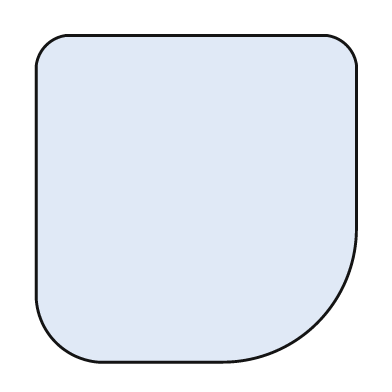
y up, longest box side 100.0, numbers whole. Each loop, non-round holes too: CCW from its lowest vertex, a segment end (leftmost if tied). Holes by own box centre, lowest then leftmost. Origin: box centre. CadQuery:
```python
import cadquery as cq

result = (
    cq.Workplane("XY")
    .moveTo(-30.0, -50.0)
    .lineTo(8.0, -50.0)
    .threePointArc((37.0, -38.0), (49.0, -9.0))
    .lineTo(49.0, 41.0)
    .threePointArc((46.0, 47.0), (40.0, 50.0))
    .lineTo(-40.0, 50.0)
    .threePointArc((-46.0, 47.0), (-49.0, 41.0))
    .lineTo(-49.0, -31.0)
    .threePointArc((-43.0, -44.0), (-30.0, -50.0))
    .close()
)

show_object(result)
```